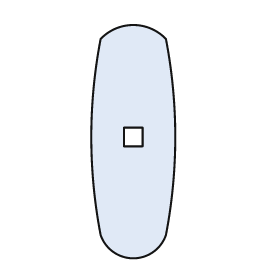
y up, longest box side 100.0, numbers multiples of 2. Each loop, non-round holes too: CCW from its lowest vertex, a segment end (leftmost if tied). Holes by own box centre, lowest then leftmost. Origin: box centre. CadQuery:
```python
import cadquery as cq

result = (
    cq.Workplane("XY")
    .moveTo(-14.0, -40.0)
    .threePointArc((0.0, -50.0), (14.0, -40.0))
    .threePointArc((18.0, 2.0), (14.0, 44.0))
    .threePointArc((0.0, 50.0), (-14.0, 44.0))
    .threePointArc((-18.0, 2.0), (-14.0, -40.0))
    .close()
    .moveTo(-4.0, -2.0)
    .lineTo(4.0, -2.0)
    .lineTo(4.0, 6.0)
    .lineTo(-4.0, 6.0)
    .close()
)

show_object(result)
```